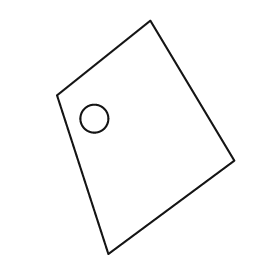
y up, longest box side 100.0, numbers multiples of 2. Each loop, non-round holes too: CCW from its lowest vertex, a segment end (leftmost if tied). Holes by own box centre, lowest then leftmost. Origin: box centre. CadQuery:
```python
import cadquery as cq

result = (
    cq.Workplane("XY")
    .moveTo(-16.0, -50.0)
    .lineTo(38.0, -10.0)
    .lineTo(2.0, 50.0)
    .lineTo(-38.0, 18.0)
    .close()
    .moveTo(-22.0, 8.0)
    .circle(6.0)
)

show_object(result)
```